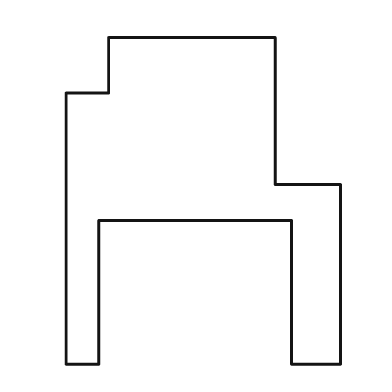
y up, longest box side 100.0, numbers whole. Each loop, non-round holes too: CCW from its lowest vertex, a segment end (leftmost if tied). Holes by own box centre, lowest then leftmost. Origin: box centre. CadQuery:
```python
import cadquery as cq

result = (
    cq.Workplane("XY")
    .moveTo(-42.0, -50.0)
    .lineTo(-32.0, -50.0)
    .lineTo(-32.0, -6.0)
    .lineTo(27.0, -6.0)
    .lineTo(27.0, -50.0)
    .lineTo(42.0, -50.0)
    .lineTo(42.0, 5.0)
    .lineTo(22.0, 5.0)
    .lineTo(22.0, 50.0)
    .lineTo(-29.0, 50.0)
    .lineTo(-29.0, 33.0)
    .lineTo(-42.0, 33.0)
    .close()
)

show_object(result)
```